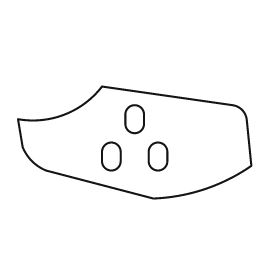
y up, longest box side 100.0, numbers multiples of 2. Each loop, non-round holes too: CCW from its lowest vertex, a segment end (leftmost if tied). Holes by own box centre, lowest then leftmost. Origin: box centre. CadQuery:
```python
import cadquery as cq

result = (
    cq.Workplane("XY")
    .moveTo(8.0, -24.0)
    .threePointArc((30.0, -20.0), (50.0, -10.0))
    .lineTo(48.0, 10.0)
    .threePointArc((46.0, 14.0), (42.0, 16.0))
    .lineTo(-14.0, 24.0)
    .threePointArc((-30.0, 12.0), (-50.0, 10.0))
    .lineTo(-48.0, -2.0)
    .threePointArc((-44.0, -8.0), (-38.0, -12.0))
    .close()
    .moveTo(-14.0, -8.0)
    .threePointArc((-10.0, -12.0), (-6.0, -8.0))
    .lineTo(-6.0, -4.0)
    .threePointArc((-10.0, 0.0), (-14.0, -4.0))
    .close()
    .moveTo(6.0, -8.0)
    .threePointArc((10.0, -12.0), (14.0, -8.0))
    .lineTo(14.0, -4.0)
    .threePointArc((10.0, 0.0), (6.0, -4.0))
    .close()
    .moveTo(-4.0, 8.0)
    .threePointArc((0.0, 4.0), (4.0, 8.0))
    .lineTo(4.0, 12.0)
    .threePointArc((0.0, 16.0), (-4.0, 12.0))
    .close()
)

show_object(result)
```